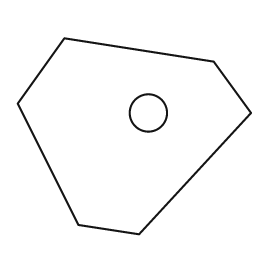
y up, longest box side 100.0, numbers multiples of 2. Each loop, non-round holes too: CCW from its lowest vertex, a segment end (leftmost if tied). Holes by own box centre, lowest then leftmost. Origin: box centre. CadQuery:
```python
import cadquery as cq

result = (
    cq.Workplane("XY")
    .moveTo(2.0, -42.0)
    .lineTo(50.0, 10.0)
    .lineTo(34.0, 32.0)
    .lineTo(-30.0, 42.0)
    .lineTo(-50.0, 14.0)
    .lineTo(-24.0, -38.0)
    .close()
    .moveTo(6.0, 10.0)
    .circle(8.0)
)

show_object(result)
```